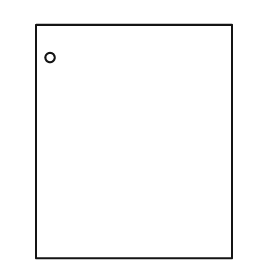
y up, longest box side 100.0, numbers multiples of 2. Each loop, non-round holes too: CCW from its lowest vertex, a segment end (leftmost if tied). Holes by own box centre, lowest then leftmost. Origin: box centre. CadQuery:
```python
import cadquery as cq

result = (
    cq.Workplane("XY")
    .moveTo(-42.0, -50.0)
    .lineTo(42.0, -50.0)
    .lineTo(42.0, 50.0)
    .lineTo(-42.0, 50.0)
    .close()
    .moveTo(-36.0, 36.0)
    .circle(2.0)
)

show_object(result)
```